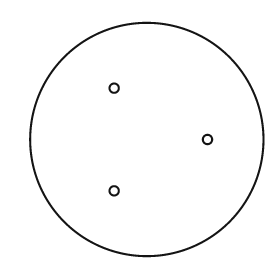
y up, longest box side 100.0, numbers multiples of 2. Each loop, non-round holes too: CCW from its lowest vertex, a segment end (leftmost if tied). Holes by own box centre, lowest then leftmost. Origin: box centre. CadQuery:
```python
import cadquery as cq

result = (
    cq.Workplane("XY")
    .moveTo(0.0, 0.0)
    .circle(50.0)
    .moveTo(-14.0, -22.0)
    .circle(2.0)
    .moveTo(26.0, 0.0)
    .circle(2.0)
    .moveTo(-14.0, 22.0)
    .circle(2.0)
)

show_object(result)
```